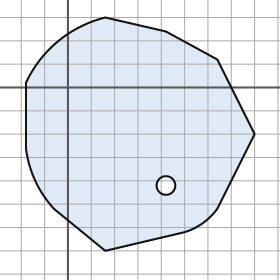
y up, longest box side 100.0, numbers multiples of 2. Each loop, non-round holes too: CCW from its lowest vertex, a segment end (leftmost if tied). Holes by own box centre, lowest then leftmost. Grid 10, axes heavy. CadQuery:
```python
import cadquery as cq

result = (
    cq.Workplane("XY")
    .moveTo(16.0, -70.0)
    .lineTo(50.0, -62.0)
    .threePointArc((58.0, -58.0), (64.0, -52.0))
    .lineTo(80.0, -20.0)
    .lineTo(64.0, 12.0)
    .lineTo(42.0, 24.0)
    .lineTo(16.0, 30.0)
    .threePointArc((-4.0, 20.0), (-18.0, 2.0))
    .lineTo(-18.0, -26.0)
    .threePointArc((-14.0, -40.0), (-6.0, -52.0))
    .close()
    .moveTo(42.0, -42.0)
    .circle(4.0)
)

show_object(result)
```